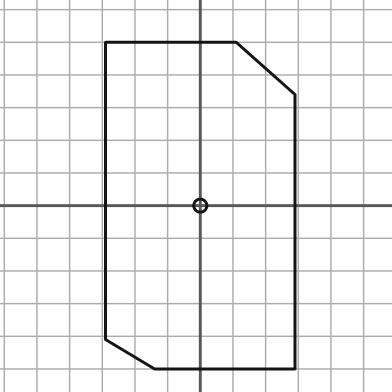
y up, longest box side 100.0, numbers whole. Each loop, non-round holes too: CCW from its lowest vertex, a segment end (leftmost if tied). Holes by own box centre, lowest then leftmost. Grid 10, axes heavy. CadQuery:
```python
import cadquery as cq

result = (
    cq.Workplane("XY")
    .moveTo(-14.0, -50.0)
    .lineTo(29.0, -50.0)
    .lineTo(29.0, 34.0)
    .lineTo(11.0, 50.0)
    .lineTo(-29.0, 50.0)
    .lineTo(-29.0, -41.0)
    .close()
    .moveTo(0.0, 0.0)
    .circle(2.0)
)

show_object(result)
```